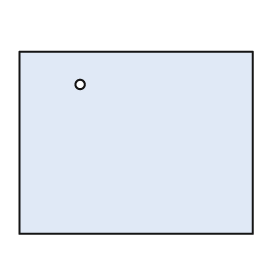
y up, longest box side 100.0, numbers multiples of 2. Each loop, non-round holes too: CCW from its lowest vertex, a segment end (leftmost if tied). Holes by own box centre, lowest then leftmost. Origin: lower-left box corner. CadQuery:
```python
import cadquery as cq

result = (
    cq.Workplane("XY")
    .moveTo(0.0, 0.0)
    .lineTo(100.0, 0.0)
    .lineTo(100.0, 78.0)
    .lineTo(0.0, 78.0)
    .close()
    .moveTo(26.0, 64.0)
    .circle(2.0)
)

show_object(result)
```